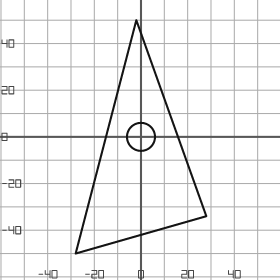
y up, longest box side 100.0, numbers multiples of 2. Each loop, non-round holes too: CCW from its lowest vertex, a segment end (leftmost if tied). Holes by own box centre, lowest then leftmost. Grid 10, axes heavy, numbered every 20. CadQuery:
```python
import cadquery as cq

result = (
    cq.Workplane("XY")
    .moveTo(-28.0, -50.0)
    .lineTo(28.0, -34.0)
    .lineTo(-2.0, 50.0)
    .close()
    .moveTo(0.0, 0.0)
    .circle(6.0)
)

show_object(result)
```